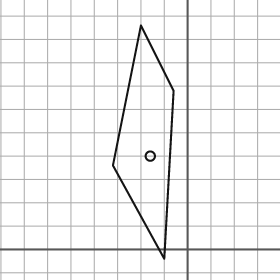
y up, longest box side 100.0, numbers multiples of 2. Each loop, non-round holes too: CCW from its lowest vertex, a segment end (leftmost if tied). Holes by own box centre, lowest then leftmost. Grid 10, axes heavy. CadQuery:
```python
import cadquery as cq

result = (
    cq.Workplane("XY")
    .moveTo(-10.0, -4.0)
    .lineTo(-6.0, 68.0)
    .lineTo(-20.0, 96.0)
    .lineTo(-32.0, 36.0)
    .close()
    .moveTo(-16.0, 40.0)
    .circle(2.0)
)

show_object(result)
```